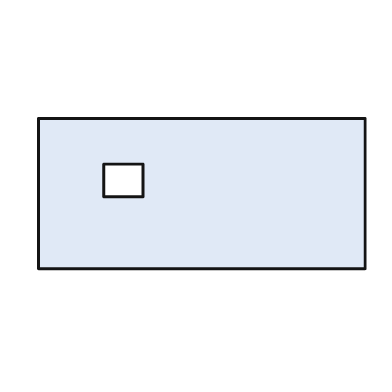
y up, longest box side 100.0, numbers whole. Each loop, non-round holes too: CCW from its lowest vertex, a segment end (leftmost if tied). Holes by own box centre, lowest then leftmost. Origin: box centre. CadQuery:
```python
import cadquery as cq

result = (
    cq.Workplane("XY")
    .moveTo(-50.0, -23.0)
    .lineTo(50.0, -23.0)
    .lineTo(50.0, 23.0)
    .lineTo(-50.0, 23.0)
    .close()
    .moveTo(-30.0, -1.0)
    .lineTo(-18.0, -1.0)
    .lineTo(-18.0, 9.0)
    .lineTo(-30.0, 9.0)
    .close()
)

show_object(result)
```